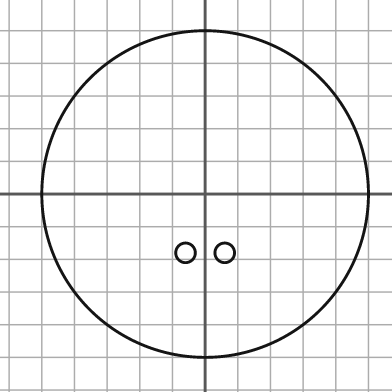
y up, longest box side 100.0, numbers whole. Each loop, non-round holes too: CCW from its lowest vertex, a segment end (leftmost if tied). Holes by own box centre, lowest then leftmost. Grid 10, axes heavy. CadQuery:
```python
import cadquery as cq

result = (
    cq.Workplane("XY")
    .moveTo(0.0, 0.0)
    .circle(50.0)
    .moveTo(-6.0, -18.0)
    .circle(3.0)
    .moveTo(6.0, -18.0)
    .circle(3.0)
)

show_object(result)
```